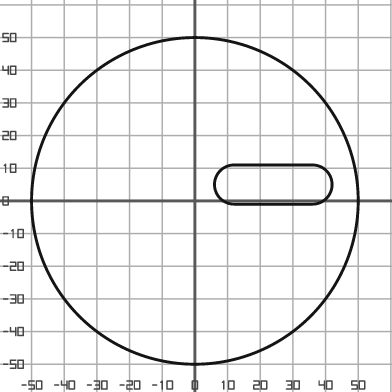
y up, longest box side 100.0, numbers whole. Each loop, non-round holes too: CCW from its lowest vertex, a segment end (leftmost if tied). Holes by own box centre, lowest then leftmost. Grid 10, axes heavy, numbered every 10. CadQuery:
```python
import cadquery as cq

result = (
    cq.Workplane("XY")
    .moveTo(0.0, 0.0)
    .circle(50.0)
    .moveTo(12.0, -1.0)
    .lineTo(36.0, -1.0)
    .threePointArc((42.0, 5.0), (36.0, 11.0))
    .lineTo(12.0, 11.0)
    .threePointArc((6.0, 5.0), (12.0, -1.0))
    .close()
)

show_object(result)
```